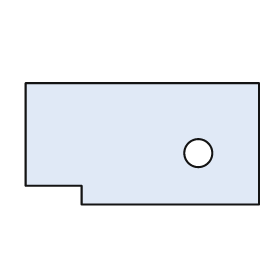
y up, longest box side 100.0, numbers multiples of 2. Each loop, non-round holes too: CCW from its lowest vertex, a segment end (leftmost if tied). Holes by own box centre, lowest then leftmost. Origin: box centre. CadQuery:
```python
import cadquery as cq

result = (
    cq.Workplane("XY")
    .moveTo(-26.0, -26.0)
    .lineTo(50.0, -26.0)
    .lineTo(50.0, 26.0)
    .lineTo(-50.0, 26.0)
    .lineTo(-50.0, -18.0)
    .lineTo(-26.0, -18.0)
    .close()
    .moveTo(24.0, -4.0)
    .circle(6.0)
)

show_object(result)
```